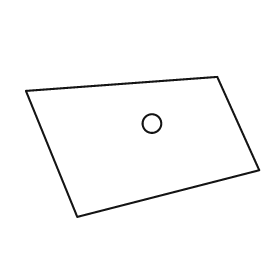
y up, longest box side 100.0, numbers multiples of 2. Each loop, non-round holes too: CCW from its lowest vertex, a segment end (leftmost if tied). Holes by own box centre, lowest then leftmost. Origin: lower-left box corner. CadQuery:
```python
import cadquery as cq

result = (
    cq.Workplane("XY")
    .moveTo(22.0, 0.0)
    .lineTo(100.0, 20.0)
    .lineTo(82.0, 60.0)
    .lineTo(0.0, 54.0)
    .close()
    .moveTo(54.0, 40.0)
    .circle(4.0)
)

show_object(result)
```